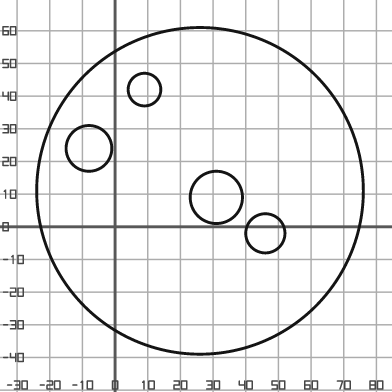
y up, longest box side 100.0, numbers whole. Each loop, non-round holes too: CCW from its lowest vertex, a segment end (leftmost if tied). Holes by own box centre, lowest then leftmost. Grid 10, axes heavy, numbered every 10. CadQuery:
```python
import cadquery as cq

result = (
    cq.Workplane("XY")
    .moveTo(26.0, 11.0)
    .circle(50.0)
    .moveTo(46.0, -2.0)
    .circle(6.0)
    .moveTo(31.0, 9.0)
    .circle(8.0)
    .moveTo(-8.0, 24.0)
    .circle(7.0)
    .moveTo(9.0, 42.0)
    .circle(5.0)
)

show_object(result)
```